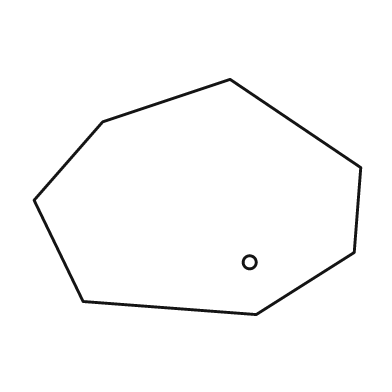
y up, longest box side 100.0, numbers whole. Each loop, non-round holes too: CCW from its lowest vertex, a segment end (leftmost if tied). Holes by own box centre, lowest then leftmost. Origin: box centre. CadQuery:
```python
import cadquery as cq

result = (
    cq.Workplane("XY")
    .moveTo(18.0, -36.0)
    .lineTo(48.0, -17.0)
    .lineTo(50.0, 9.0)
    .lineTo(10.0, 36.0)
    .lineTo(-29.0, 23.0)
    .lineTo(-50.0, -1.0)
    .lineTo(-35.0, -32.0)
    .close()
    .moveTo(16.0, -20.0)
    .circle(2.0)
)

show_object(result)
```